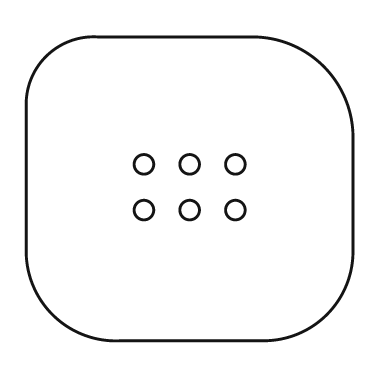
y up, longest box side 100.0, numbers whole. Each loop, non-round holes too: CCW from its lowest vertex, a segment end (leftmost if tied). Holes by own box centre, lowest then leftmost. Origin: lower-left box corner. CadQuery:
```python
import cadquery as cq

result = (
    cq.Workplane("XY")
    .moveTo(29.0, 0.0)
    .lineTo(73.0, 0.0)
    .threePointArc((92.0, 8.0), (100.0, 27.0))
    .lineTo(100.0, 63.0)
    .threePointArc((91.0, 84.0), (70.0, 93.0))
    .lineTo(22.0, 93.0)
    .threePointArc((6.0, 87.0), (0.0, 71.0))
    .lineTo(0.0, 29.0)
    .threePointArc((8.0, 8.0), (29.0, 0.0))
    .close()
    .moveTo(36.0, 40.0)
    .circle(3.0)
    .moveTo(50.0, 40.0)
    .circle(3.0)
    .moveTo(64.0, 40.0)
    .circle(3.0)
    .moveTo(36.0, 54.0)
    .circle(3.0)
    .moveTo(50.0, 54.0)
    .circle(3.0)
    .moveTo(64.0, 54.0)
    .circle(3.0)
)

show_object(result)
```